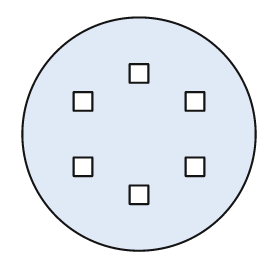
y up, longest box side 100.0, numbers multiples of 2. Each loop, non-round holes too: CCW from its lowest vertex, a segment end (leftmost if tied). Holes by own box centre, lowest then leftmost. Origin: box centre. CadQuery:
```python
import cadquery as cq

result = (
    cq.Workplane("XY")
    .moveTo(0.0, 0.0)
    .circle(50.0)
    .moveTo(-4.0, -30.0)
    .lineTo(4.0, -30.0)
    .lineTo(4.0, -22.0)
    .lineTo(-4.0, -22.0)
    .close()
    .moveTo(-28.0, -18.0)
    .lineTo(-20.0, -18.0)
    .lineTo(-20.0, -10.0)
    .lineTo(-28.0, -10.0)
    .close()
    .moveTo(20.0, -18.0)
    .lineTo(28.0, -18.0)
    .lineTo(28.0, -10.0)
    .lineTo(20.0, -10.0)
    .close()
    .moveTo(-28.0, 10.0)
    .lineTo(-20.0, 10.0)
    .lineTo(-20.0, 18.0)
    .lineTo(-28.0, 18.0)
    .close()
    .moveTo(20.0, 10.0)
    .lineTo(28.0, 10.0)
    .lineTo(28.0, 18.0)
    .lineTo(20.0, 18.0)
    .close()
    .moveTo(-4.0, 22.0)
    .lineTo(4.0, 22.0)
    .lineTo(4.0, 30.0)
    .lineTo(-4.0, 30.0)
    .close()
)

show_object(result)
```